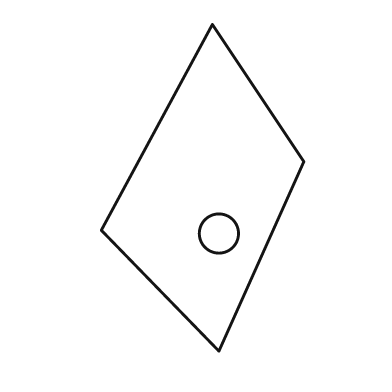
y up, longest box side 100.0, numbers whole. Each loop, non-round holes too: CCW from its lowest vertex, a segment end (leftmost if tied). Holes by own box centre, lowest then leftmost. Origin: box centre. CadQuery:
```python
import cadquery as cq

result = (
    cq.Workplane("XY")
    .moveTo(5.0, -50.0)
    .lineTo(31.0, 8.0)
    .lineTo(3.0, 50.0)
    .lineTo(-31.0, -13.0)
    .close()
    .moveTo(5.0, -14.0)
    .circle(6.0)
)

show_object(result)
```